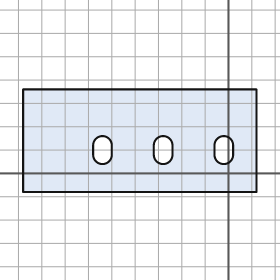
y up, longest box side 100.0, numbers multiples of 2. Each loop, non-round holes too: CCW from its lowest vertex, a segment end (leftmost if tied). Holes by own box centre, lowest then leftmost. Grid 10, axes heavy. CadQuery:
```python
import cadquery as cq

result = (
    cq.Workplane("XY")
    .moveTo(-88.0, -8.0)
    .lineTo(12.0, -8.0)
    .lineTo(12.0, 36.0)
    .lineTo(-88.0, 36.0)
    .close()
    .moveTo(-58.0, 8.0)
    .threePointArc((-54.0, 4.0), (-50.0, 8.0))
    .lineTo(-50.0, 12.0)
    .threePointArc((-54.0, 16.0), (-58.0, 12.0))
    .close()
    .moveTo(-32.0, 8.0)
    .threePointArc((-28.0, 4.0), (-24.0, 8.0))
    .lineTo(-24.0, 12.0)
    .threePointArc((-28.0, 16.0), (-32.0, 12.0))
    .close()
    .moveTo(-6.0, 8.0)
    .threePointArc((-2.0, 4.0), (2.0, 8.0))
    .lineTo(2.0, 12.0)
    .threePointArc((-2.0, 16.0), (-6.0, 12.0))
    .close()
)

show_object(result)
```